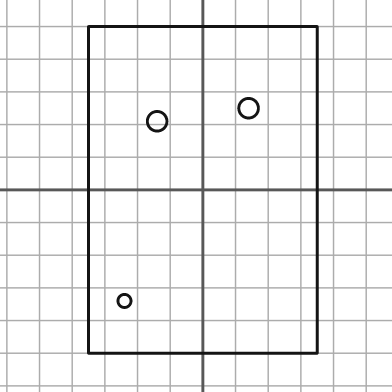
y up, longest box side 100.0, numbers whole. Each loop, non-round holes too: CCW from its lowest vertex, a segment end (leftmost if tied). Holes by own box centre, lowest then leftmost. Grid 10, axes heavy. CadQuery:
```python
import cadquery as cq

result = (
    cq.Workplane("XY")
    .moveTo(-35.0, -50.0)
    .lineTo(35.0, -50.0)
    .lineTo(35.0, 50.0)
    .lineTo(-35.0, 50.0)
    .close()
    .moveTo(-24.0, -34.0)
    .circle(2.0)
    .moveTo(-14.0, 21.0)
    .circle(3.0)
    .moveTo(14.0, 25.0)
    .circle(3.0)
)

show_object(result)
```